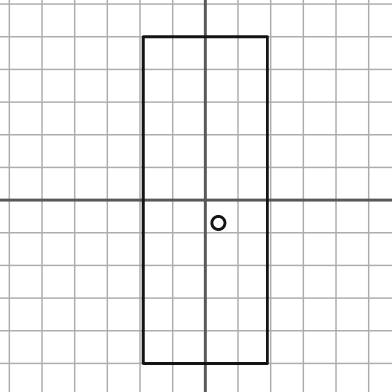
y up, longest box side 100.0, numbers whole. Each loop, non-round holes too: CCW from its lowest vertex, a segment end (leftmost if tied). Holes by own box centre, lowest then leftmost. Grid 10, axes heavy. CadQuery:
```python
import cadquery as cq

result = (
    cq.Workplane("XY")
    .moveTo(-19.0, -50.0)
    .lineTo(19.0, -50.0)
    .lineTo(19.0, 50.0)
    .lineTo(-19.0, 50.0)
    .close()
    .moveTo(4.0, -7.0)
    .circle(2.0)
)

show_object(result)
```